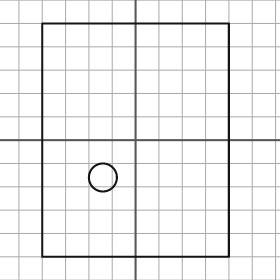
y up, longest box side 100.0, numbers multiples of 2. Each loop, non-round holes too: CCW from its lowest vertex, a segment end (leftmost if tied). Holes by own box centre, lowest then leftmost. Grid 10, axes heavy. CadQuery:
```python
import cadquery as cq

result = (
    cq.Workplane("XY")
    .moveTo(-40.0, -50.0)
    .lineTo(40.0, -50.0)
    .lineTo(40.0, 50.0)
    .lineTo(-40.0, 50.0)
    .close()
    .moveTo(-14.0, -16.0)
    .circle(6.0)
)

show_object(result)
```